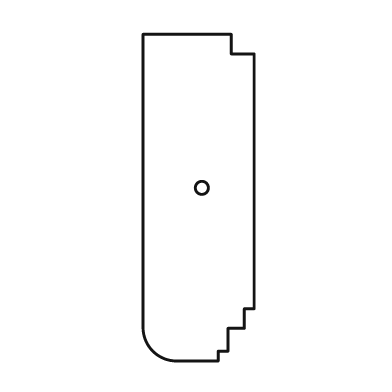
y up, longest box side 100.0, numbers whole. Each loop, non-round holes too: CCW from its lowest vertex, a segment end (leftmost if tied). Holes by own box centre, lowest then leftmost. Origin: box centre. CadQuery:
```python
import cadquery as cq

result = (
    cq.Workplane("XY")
    .moveTo(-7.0, -50.0)
    .lineTo(6.0, -50.0)
    .lineTo(6.0, -47.0)
    .lineTo(9.0, -47.0)
    .lineTo(9.0, -40.0)
    .lineTo(14.0, -40.0)
    .lineTo(14.0, -34.0)
    .lineTo(17.0, -34.0)
    .lineTo(17.0, 44.0)
    .lineTo(10.0, 44.0)
    .lineTo(10.0, 50.0)
    .lineTo(-17.0, 50.0)
    .lineTo(-17.0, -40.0)
    .threePointArc((-14.0, -47.0), (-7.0, -50.0))
    .close()
    .moveTo(1.0, 3.0)
    .circle(2.0)
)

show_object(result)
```